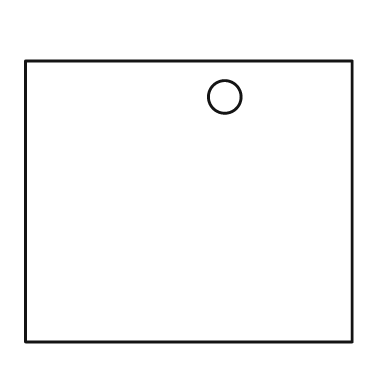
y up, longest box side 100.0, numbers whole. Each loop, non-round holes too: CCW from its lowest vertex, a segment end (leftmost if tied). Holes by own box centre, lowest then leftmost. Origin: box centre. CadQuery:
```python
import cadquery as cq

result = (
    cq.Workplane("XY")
    .moveTo(-50.0, -43.0)
    .lineTo(50.0, -43.0)
    .lineTo(50.0, 43.0)
    .lineTo(-50.0, 43.0)
    .close()
    .moveTo(11.0, 32.0)
    .circle(5.0)
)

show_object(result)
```